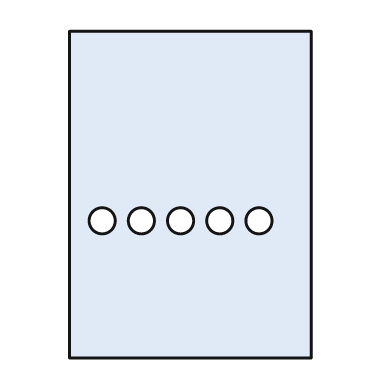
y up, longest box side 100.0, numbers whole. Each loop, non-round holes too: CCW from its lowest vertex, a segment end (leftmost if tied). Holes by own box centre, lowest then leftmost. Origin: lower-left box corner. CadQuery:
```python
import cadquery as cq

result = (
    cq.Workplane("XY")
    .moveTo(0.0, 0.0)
    .lineTo(74.0, 0.0)
    .lineTo(74.0, 100.0)
    .lineTo(0.0, 100.0)
    .close()
    .moveTo(10.0, 42.0)
    .circle(4.0)
    .moveTo(22.0, 42.0)
    .circle(4.0)
    .moveTo(34.0, 42.0)
    .circle(4.0)
    .moveTo(46.0, 42.0)
    .circle(4.0)
    .moveTo(58.0, 42.0)
    .circle(4.0)
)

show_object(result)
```